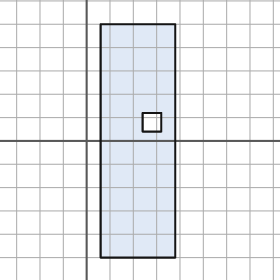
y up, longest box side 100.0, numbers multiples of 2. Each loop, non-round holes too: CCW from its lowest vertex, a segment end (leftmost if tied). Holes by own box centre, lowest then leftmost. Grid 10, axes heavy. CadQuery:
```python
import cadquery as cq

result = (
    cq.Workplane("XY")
    .moveTo(6.0, -50.0)
    .lineTo(38.0, -50.0)
    .lineTo(38.0, 50.0)
    .lineTo(6.0, 50.0)
    .close()
    .moveTo(24.0, 4.0)
    .lineTo(32.0, 4.0)
    .lineTo(32.0, 12.0)
    .lineTo(24.0, 12.0)
    .close()
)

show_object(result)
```